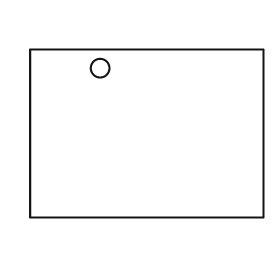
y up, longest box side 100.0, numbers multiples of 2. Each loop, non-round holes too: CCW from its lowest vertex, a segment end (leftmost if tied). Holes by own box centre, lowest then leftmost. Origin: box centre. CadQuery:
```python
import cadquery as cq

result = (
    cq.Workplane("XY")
    .moveTo(-50.0, -36.0)
    .lineTo(50.0, -36.0)
    .lineTo(50.0, 36.0)
    .lineTo(-50.0, 36.0)
    .close()
    .moveTo(-20.0, 28.0)
    .circle(4.0)
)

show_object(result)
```